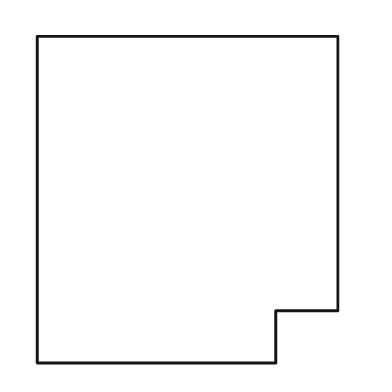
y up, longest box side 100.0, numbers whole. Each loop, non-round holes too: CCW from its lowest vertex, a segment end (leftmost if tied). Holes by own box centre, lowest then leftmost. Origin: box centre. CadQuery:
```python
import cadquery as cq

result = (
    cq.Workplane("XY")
    .moveTo(-46.0, -50.0)
    .lineTo(27.0, -50.0)
    .lineTo(27.0, -34.0)
    .lineTo(46.0, -34.0)
    .lineTo(46.0, 50.0)
    .lineTo(-46.0, 50.0)
    .close()
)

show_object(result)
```